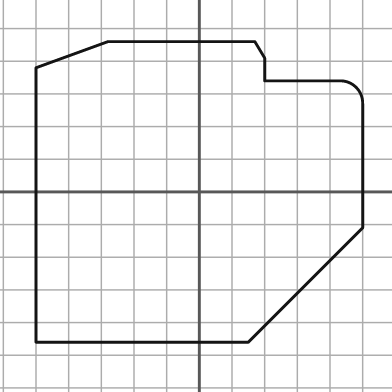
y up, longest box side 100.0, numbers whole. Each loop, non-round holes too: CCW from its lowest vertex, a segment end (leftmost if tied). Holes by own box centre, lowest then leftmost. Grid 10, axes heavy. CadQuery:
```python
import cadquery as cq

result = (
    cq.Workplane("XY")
    .moveTo(-50.0, -46.0)
    .lineTo(15.0, -46.0)
    .lineTo(50.0, -11.0)
    .lineTo(50.0, 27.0)
    .threePointArc((48.0, 32.0), (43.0, 34.0))
    .lineTo(20.0, 34.0)
    .lineTo(20.0, 41.0)
    .lineTo(17.0, 46.0)
    .lineTo(-28.0, 46.0)
    .lineTo(-50.0, 38.0)
    .close()
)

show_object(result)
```